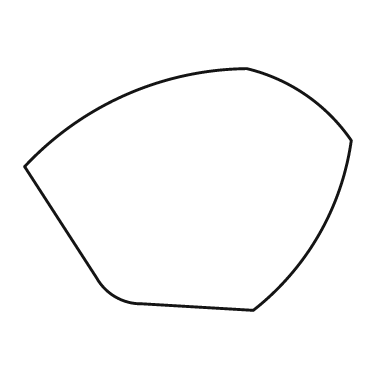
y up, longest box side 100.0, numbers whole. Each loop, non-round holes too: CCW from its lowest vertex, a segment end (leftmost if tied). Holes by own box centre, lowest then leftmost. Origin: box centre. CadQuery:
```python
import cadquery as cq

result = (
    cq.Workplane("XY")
    .moveTo(20.0, -37.0)
    .threePointArc((40.0, -14.0), (50.0, 15.0))
    .threePointArc((36.0, 29.0), (18.0, 37.0))
    .threePointArc((-19.0, 29.0), (-50.0, 7.0))
    .lineTo(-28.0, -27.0)
    .threePointArc((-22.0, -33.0), (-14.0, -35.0))
    .close()
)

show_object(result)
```